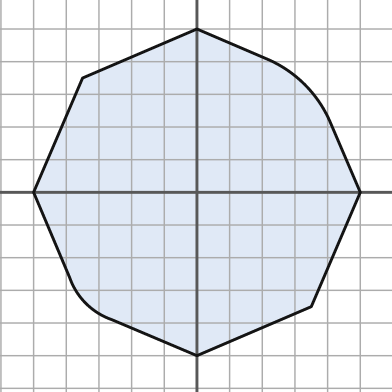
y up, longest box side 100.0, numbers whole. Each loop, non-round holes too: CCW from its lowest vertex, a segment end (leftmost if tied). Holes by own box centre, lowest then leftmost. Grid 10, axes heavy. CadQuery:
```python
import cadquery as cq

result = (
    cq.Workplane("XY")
    .moveTo(0.0, -50.0)
    .lineTo(35.0, -35.0)
    .lineTo(50.0, 0.0)
    .lineTo(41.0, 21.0)
    .threePointArc((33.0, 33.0), (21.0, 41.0))
    .lineTo(0.0, 50.0)
    .lineTo(-35.0, 35.0)
    .lineTo(-50.0, 0.0)
    .lineTo(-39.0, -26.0)
    .threePointArc((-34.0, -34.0), (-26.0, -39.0))
    .close()
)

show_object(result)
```